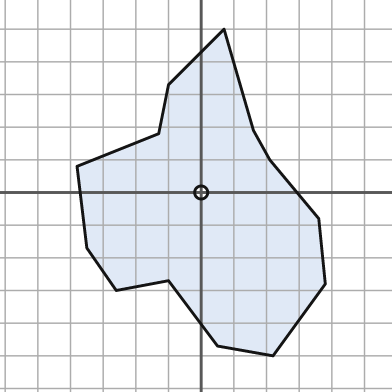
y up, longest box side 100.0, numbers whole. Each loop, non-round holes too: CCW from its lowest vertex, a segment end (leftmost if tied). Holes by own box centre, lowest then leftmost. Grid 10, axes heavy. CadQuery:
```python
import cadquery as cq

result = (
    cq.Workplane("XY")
    .moveTo(22.0, -50.0)
    .lineTo(38.0, -28.0)
    .lineTo(36.0, -8.0)
    .lineTo(21.0, 10.0)
    .lineTo(16.0, 19.0)
    .lineTo(7.0, 50.0)
    .lineTo(-10.0, 33.0)
    .lineTo(-13.0, 18.0)
    .lineTo(-38.0, 8.0)
    .lineTo(-35.0, -17.0)
    .lineTo(-26.0, -30.0)
    .lineTo(-10.0, -27.0)
    .lineTo(5.0, -47.0)
    .close()
    .moveTo(0.0, 0.0)
    .circle(2.0)
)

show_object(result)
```